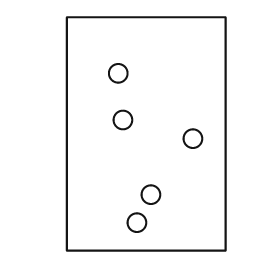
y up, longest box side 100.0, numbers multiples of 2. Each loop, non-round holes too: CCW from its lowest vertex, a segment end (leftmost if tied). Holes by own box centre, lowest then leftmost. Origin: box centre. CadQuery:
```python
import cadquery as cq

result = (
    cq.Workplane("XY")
    .moveTo(-34.0, -50.0)
    .lineTo(34.0, -50.0)
    .lineTo(34.0, 50.0)
    .lineTo(-34.0, 50.0)
    .close()
    .moveTo(-4.0, -38.0)
    .circle(4.0)
    .moveTo(2.0, -26.0)
    .circle(4.0)
    .moveTo(20.0, -2.0)
    .circle(4.0)
    .moveTo(-10.0, 6.0)
    .circle(4.0)
    .moveTo(-12.0, 26.0)
    .circle(4.0)
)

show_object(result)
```